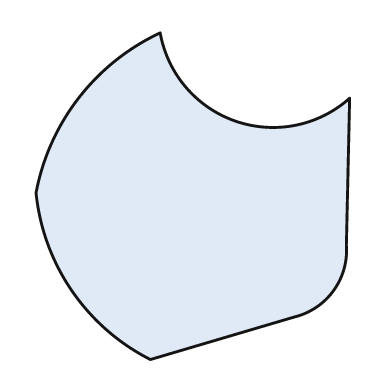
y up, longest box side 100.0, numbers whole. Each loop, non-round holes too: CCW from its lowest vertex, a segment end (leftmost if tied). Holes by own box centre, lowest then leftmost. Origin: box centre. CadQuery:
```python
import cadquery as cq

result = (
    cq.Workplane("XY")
    .moveTo(-13.0, -50.0)
    .lineTo(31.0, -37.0)
    .threePointArc((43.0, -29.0), (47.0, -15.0))
    .lineTo(48.0, 30.0)
    .threePointArc((13.0, 23.0), (-10.0, 50.0))
    .threePointArc((-35.0, 30.0), (-48.0, 1.0))
    .threePointArc((-37.0, -29.0), (-13.0, -50.0))
    .close()
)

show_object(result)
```